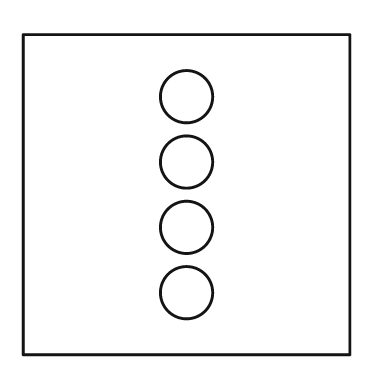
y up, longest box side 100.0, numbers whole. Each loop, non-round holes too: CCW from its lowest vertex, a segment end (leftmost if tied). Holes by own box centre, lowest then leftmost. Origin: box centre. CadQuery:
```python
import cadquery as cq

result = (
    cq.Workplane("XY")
    .moveTo(-50.0, -49.0)
    .lineTo(50.0, -49.0)
    .lineTo(50.0, 49.0)
    .lineTo(-50.0, 49.0)
    .close()
    .moveTo(0.0, -30.0)
    .circle(8.0)
    .moveTo(0.0, -10.0)
    .circle(8.0)
    .moveTo(0.0, 10.0)
    .circle(8.0)
    .moveTo(0.0, 30.0)
    .circle(8.0)
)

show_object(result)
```